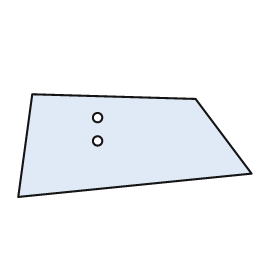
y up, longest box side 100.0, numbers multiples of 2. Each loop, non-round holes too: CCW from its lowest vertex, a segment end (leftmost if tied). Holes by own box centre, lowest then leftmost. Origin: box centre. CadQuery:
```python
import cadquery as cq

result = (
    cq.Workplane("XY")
    .moveTo(-50.0, -22.0)
    .lineTo(50.0, -12.0)
    .lineTo(26.0, 20.0)
    .lineTo(-44.0, 22.0)
    .close()
    .moveTo(-16.0, 2.0)
    .circle(2.0)
    .moveTo(-16.0, 12.0)
    .circle(2.0)
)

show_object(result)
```